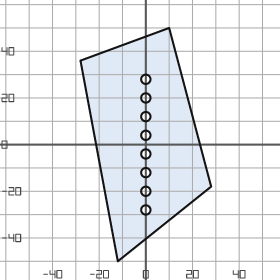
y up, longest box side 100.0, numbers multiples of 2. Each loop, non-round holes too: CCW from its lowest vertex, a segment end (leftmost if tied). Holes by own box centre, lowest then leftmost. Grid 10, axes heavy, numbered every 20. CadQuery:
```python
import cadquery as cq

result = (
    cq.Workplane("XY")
    .moveTo(-12.0, -50.0)
    .lineTo(28.0, -18.0)
    .lineTo(10.0, 50.0)
    .lineTo(-28.0, 36.0)
    .close()
    .moveTo(0.0, -28.0)
    .circle(2.0)
    .moveTo(0.0, -20.0)
    .circle(2.0)
    .moveTo(0.0, -12.0)
    .circle(2.0)
    .moveTo(0.0, -4.0)
    .circle(2.0)
    .moveTo(0.0, 4.0)
    .circle(2.0)
    .moveTo(0.0, 12.0)
    .circle(2.0)
    .moveTo(0.0, 20.0)
    .circle(2.0)
    .moveTo(0.0, 28.0)
    .circle(2.0)
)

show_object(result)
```